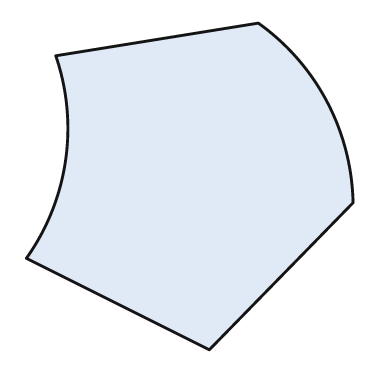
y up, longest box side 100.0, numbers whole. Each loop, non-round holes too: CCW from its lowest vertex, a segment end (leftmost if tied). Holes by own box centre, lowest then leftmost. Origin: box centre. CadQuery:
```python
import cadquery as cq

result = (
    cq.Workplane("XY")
    .moveTo(6.0, -50.0)
    .lineTo(50.0, -5.0)
    .threePointArc((42.0, 26.0), (21.0, 50.0))
    .lineTo(-41.0, 40.0)
    .threePointArc((-38.0, 8.0), (-50.0, -22.0))
    .close()
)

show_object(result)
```